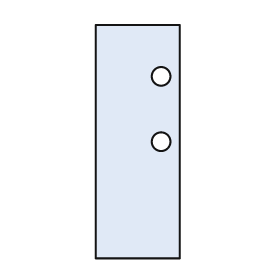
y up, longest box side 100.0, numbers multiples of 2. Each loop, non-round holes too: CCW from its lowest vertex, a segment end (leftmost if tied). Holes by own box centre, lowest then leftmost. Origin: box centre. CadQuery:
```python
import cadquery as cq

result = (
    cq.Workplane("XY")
    .moveTo(-18.0, -50.0)
    .lineTo(18.0, -50.0)
    .lineTo(18.0, 50.0)
    .lineTo(-18.0, 50.0)
    .close()
    .moveTo(10.0, 0.0)
    .circle(4.0)
    .moveTo(10.0, 28.0)
    .circle(4.0)
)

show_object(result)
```